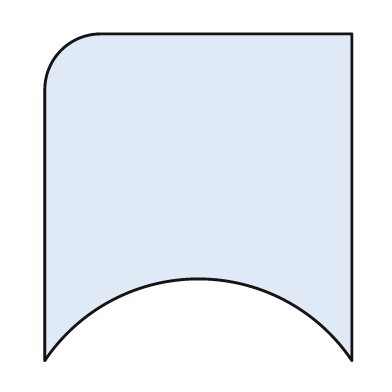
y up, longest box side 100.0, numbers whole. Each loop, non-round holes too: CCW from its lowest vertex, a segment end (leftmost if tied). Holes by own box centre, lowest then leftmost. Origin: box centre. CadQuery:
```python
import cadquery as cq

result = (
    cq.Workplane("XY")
    .moveTo(-47.0, -50.0)
    .threePointArc((0.0, -25.0), (47.0, -50.0))
    .lineTo(47.0, 50.0)
    .lineTo(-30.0, 50.0)
    .threePointArc((-42.0, 45.0), (-47.0, 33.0))
    .close()
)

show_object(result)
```